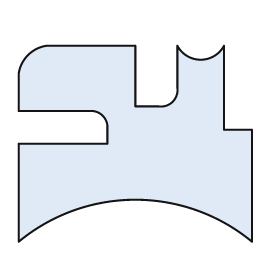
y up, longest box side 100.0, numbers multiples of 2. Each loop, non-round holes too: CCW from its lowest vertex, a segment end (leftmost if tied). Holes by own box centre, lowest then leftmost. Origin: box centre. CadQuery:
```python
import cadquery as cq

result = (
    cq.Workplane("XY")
    .moveTo(-50.0, -42.0)
    .threePointArc((0.0, -24.0), (50.0, -42.0))
    .lineTo(50.0, 6.0)
    .lineTo(38.0, 6.0)
    .lineTo(38.0, 42.0)
    .threePointArc((28.0, 36.0), (18.0, 42.0))
    .lineTo(18.0, 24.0)
    .threePointArc((16.0, 18.0), (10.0, 16.0))
    .lineTo(0.0, 16.0)
    .lineTo(0.0, 42.0)
    .lineTo(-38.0, 42.0)
    .threePointArc((-46.0, 38.0), (-50.0, 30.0))
    .lineTo(-50.0, 14.0)
    .lineTo(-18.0, 14.0)
    .threePointArc((-14.0, 12.0), (-12.0, 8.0))
    .lineTo(-12.0, 0.0)
    .lineTo(-50.0, 0.0)
    .close()
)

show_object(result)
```